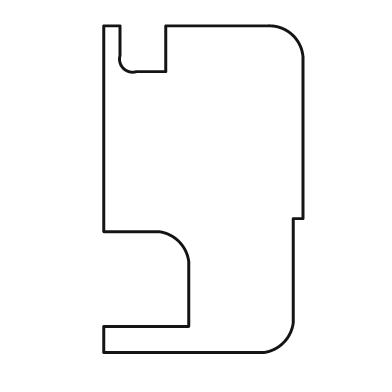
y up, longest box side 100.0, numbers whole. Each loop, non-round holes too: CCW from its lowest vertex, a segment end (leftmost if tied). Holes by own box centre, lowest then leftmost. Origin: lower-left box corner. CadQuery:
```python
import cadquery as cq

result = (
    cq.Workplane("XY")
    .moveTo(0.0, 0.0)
    .lineTo(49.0, 0.0)
    .threePointArc((55.0, 3.0), (58.0, 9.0))
    .lineTo(58.0, 41.0)
    .lineTo(61.0, 41.0)
    .lineTo(61.0, 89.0)
    .threePointArc((58.0, 97.0), (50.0, 100.0))
    .lineTo(19.0, 100.0)
    .lineTo(19.0, 86.0)
    .lineTo(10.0, 86.0)
    .threePointArc((6.0, 87.0), (5.0, 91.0))
    .lineTo(5.0, 100.0)
    .lineTo(0.0, 100.0)
    .lineTo(0.0, 37.0)
    .lineTo(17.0, 37.0)
    .threePointArc((23.0, 34.0), (26.0, 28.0))
    .lineTo(26.0, 8.0)
    .lineTo(0.0, 8.0)
    .close()
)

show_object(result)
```